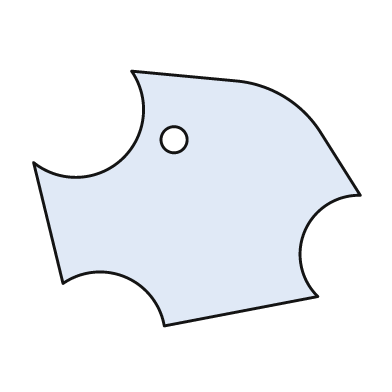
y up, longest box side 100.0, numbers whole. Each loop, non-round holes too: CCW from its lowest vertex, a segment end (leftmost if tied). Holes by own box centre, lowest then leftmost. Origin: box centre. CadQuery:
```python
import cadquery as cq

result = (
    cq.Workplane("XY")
    .moveTo(-10.0, -39.0)
    .lineTo(37.0, -30.0)
    .threePointArc((33.0, -10.0), (50.0, 1.0))
    .lineTo(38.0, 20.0)
    .threePointArc((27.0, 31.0), (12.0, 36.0))
    .lineTo(-20.0, 39.0)
    .threePointArc((-23.0, 12.0), (-50.0, 11.0))
    .lineTo(-41.0, -26.0)
    .threePointArc((-22.0, -24.0), (-10.0, -39.0))
    .close()
    .moveTo(-7.0, 18.0)
    .circle(4.0)
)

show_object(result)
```